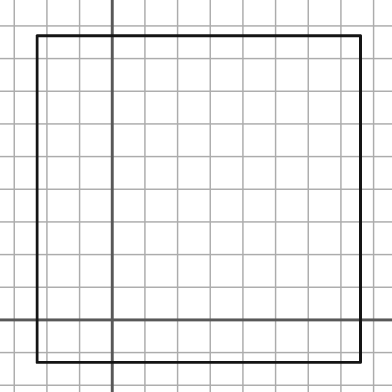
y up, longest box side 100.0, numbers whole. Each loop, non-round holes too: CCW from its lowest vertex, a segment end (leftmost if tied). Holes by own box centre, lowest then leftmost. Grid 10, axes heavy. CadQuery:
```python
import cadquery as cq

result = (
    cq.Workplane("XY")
    .moveTo(-23.0, -13.0)
    .lineTo(76.0, -13.0)
    .lineTo(76.0, 87.0)
    .lineTo(-23.0, 87.0)
    .close()
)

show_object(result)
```